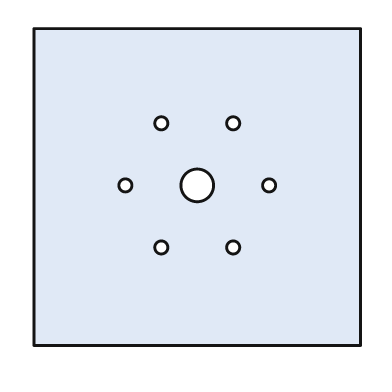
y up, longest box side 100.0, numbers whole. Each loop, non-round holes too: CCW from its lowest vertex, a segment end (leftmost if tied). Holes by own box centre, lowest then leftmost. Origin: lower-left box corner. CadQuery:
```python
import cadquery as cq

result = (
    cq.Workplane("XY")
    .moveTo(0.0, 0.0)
    .lineTo(100.0, 0.0)
    .lineTo(100.0, 97.0)
    .lineTo(0.0, 97.0)
    .close()
    .moveTo(39.0, 30.0)
    .circle(2.0)
    .moveTo(61.0, 30.0)
    .circle(2.0)
    .moveTo(28.0, 49.0)
    .circle(2.0)
    .moveTo(50.0, 49.0)
    .circle(5.0)
    .moveTo(72.0, 49.0)
    .circle(2.0)
    .moveTo(39.0, 68.0)
    .circle(2.0)
    .moveTo(61.0, 68.0)
    .circle(2.0)
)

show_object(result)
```